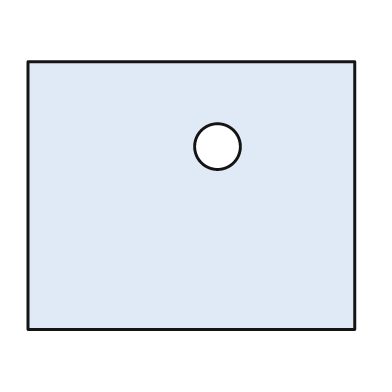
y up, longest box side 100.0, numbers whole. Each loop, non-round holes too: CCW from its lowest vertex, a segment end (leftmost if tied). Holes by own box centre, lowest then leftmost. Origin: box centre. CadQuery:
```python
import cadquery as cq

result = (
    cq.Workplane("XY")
    .moveTo(-50.0, -41.0)
    .lineTo(50.0, -41.0)
    .lineTo(50.0, 41.0)
    .lineTo(-50.0, 41.0)
    .close()
    .moveTo(8.0, 15.0)
    .circle(7.0)
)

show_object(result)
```